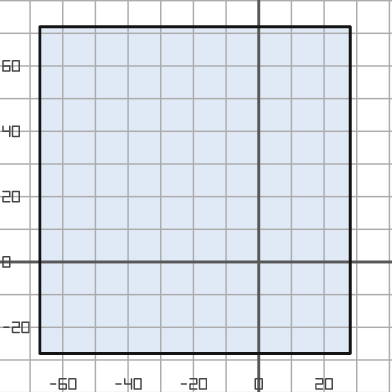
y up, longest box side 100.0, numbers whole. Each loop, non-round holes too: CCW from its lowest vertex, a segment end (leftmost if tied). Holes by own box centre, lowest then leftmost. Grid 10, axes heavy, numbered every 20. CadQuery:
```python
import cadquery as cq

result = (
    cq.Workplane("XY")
    .moveTo(-67.0, -28.0)
    .lineTo(28.0, -28.0)
    .lineTo(28.0, 72.0)
    .lineTo(-67.0, 72.0)
    .close()
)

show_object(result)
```